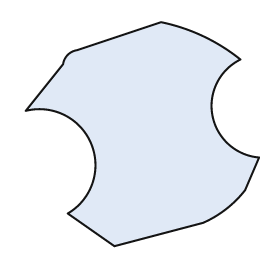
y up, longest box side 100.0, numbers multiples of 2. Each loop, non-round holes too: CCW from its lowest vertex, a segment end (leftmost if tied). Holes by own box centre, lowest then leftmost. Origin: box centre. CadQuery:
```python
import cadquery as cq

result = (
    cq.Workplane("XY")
    .moveTo(-12.0, -48.0)
    .lineTo(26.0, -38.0)
    .threePointArc((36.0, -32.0), (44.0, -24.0))
    .lineTo(50.0, -10.0)
    .threePointArc((30.0, 8.0), (42.0, 32.0))
    .threePointArc((26.0, 42.0), (8.0, 48.0))
    .lineTo(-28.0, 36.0)
    .threePointArc((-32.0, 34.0), (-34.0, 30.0))
    .lineTo(-50.0, 10.0)
    .threePointArc((-22.0, -4.0), (-32.0, -34.0))
    .close()
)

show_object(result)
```